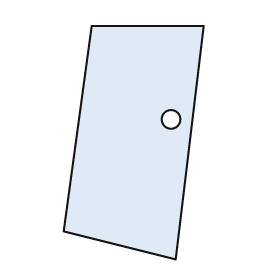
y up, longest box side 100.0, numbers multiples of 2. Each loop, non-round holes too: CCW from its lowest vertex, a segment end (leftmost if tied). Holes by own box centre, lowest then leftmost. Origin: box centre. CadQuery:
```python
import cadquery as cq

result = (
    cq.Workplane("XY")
    .moveTo(18.0, -50.0)
    .lineTo(30.0, 50.0)
    .lineTo(-18.0, 50.0)
    .lineTo(-30.0, -38.0)
    .close()
    .moveTo(16.0, 10.0)
    .circle(4.0)
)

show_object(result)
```